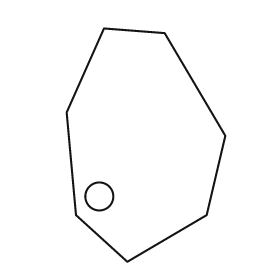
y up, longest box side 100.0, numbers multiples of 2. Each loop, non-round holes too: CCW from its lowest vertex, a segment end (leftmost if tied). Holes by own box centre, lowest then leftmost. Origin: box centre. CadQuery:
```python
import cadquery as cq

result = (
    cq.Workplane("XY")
    .moveTo(-8.0, -50.0)
    .lineTo(26.0, -30.0)
    .lineTo(34.0, 4.0)
    .lineTo(8.0, 48.0)
    .lineTo(-18.0, 50.0)
    .lineTo(-34.0, 14.0)
    .lineTo(-30.0, -30.0)
    .close()
    .moveTo(-20.0, -22.0)
    .circle(6.0)
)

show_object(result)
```